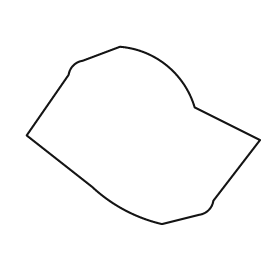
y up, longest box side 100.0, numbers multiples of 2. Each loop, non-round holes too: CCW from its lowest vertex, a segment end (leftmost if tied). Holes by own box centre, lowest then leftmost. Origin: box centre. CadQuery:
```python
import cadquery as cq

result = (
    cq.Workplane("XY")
    .moveTo(8.0, -38.0)
    .lineTo(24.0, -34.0)
    .threePointArc((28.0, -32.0), (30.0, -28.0))
    .lineTo(50.0, -2.0)
    .lineTo(22.0, 12.0)
    .threePointArc((10.0, 30.0), (-10.0, 38.0))
    .lineTo(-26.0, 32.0)
    .threePointArc((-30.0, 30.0), (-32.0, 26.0))
    .lineTo(-50.0, 0.0)
    .lineTo(-22.0, -22.0)
    .threePointArc((-8.0, -32.0), (8.0, -38.0))
    .close()
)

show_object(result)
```